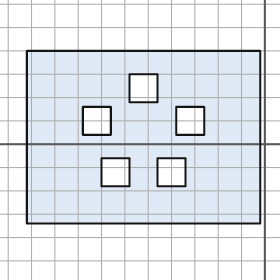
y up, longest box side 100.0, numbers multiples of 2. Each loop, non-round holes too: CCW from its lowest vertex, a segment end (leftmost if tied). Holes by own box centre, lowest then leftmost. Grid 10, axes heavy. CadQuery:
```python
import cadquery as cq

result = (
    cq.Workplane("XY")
    .moveTo(-102.0, -34.0)
    .lineTo(-2.0, -34.0)
    .lineTo(-2.0, 40.0)
    .lineTo(-102.0, 40.0)
    .close()
    .moveTo(-70.0, -18.0)
    .lineTo(-58.0, -18.0)
    .lineTo(-58.0, -6.0)
    .lineTo(-70.0, -6.0)
    .close()
    .moveTo(-46.0, -18.0)
    .lineTo(-34.0, -18.0)
    .lineTo(-34.0, -6.0)
    .lineTo(-46.0, -6.0)
    .close()
    .moveTo(-78.0, 4.0)
    .lineTo(-66.0, 4.0)
    .lineTo(-66.0, 16.0)
    .lineTo(-78.0, 16.0)
    .close()
    .moveTo(-38.0, 4.0)
    .lineTo(-26.0, 4.0)
    .lineTo(-26.0, 16.0)
    .lineTo(-38.0, 16.0)
    .close()
    .moveTo(-58.0, 18.0)
    .lineTo(-46.0, 18.0)
    .lineTo(-46.0, 30.0)
    .lineTo(-58.0, 30.0)
    .close()
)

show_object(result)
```